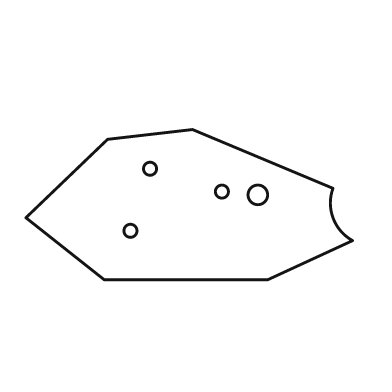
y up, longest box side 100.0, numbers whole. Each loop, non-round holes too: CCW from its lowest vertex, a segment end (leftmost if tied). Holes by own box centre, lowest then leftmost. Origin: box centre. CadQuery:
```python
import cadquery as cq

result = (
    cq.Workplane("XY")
    .moveTo(-26.0, -23.0)
    .lineTo(24.0, -23.0)
    .lineTo(50.0, -11.0)
    .threePointArc((44.0, -4.0), (44.0, 5.0))
    .lineTo(1.0, 23.0)
    .lineTo(-25.0, 20.0)
    .lineTo(-50.0, -4.0)
    .close()
    .moveTo(-18.0, -8.0)
    .circle(2.0)
    .moveTo(21.0, 3.0)
    .circle(3.0)
    .moveTo(10.0, 4.0)
    .circle(2.0)
    .moveTo(-12.0, 11.0)
    .circle(2.0)
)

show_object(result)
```